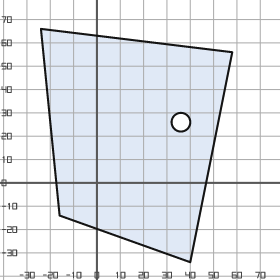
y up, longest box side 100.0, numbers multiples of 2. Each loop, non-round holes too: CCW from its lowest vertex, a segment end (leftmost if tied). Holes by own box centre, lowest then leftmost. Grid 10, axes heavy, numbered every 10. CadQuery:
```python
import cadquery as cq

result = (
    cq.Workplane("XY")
    .moveTo(40.0, -34.0)
    .lineTo(58.0, 56.0)
    .lineTo(-24.0, 66.0)
    .lineTo(-16.0, -14.0)
    .close()
    .moveTo(36.0, 26.0)
    .circle(4.0)
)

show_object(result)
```